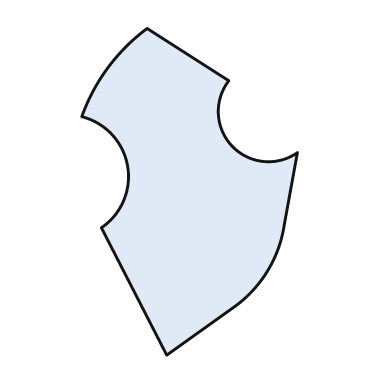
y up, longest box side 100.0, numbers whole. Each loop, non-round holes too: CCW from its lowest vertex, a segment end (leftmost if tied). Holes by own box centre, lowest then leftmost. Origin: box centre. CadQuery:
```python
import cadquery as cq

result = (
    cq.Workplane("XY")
    .moveTo(-7.0, -50.0)
    .lineTo(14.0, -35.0)
    .threePointArc((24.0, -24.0), (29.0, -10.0))
    .lineTo(33.0, 12.0)
    .threePointArc((13.0, 14.0), (12.0, 34.0))
    .lineTo(-13.0, 50.0)
    .threePointArc((-25.0, 38.0), (-33.0, 23.0))
    .threePointArc((-19.0, 8.0), (-27.0, -11.0))
    .close()
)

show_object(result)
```